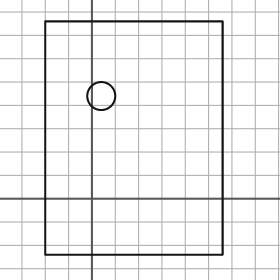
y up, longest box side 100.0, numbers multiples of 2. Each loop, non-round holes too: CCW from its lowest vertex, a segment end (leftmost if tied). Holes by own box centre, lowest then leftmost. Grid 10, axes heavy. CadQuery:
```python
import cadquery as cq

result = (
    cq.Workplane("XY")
    .moveTo(-20.0, -24.0)
    .lineTo(56.0, -24.0)
    .lineTo(56.0, 76.0)
    .lineTo(-20.0, 76.0)
    .close()
    .moveTo(4.0, 44.0)
    .circle(6.0)
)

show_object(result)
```